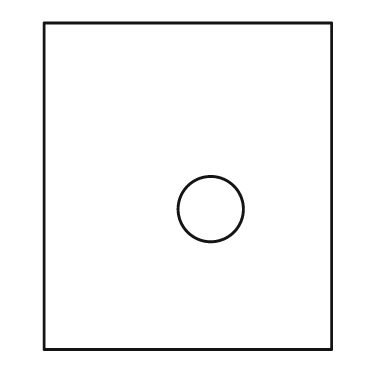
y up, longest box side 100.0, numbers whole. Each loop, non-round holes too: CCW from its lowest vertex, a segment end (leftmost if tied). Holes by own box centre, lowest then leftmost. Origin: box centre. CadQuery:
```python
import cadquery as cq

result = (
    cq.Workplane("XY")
    .moveTo(-44.0, -50.0)
    .lineTo(44.0, -50.0)
    .lineTo(44.0, 50.0)
    .lineTo(-44.0, 50.0)
    .close()
    .moveTo(7.0, -7.0)
    .circle(10.0)
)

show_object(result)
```